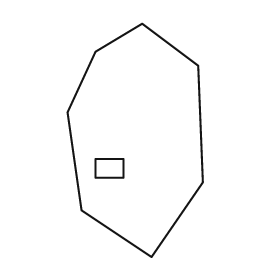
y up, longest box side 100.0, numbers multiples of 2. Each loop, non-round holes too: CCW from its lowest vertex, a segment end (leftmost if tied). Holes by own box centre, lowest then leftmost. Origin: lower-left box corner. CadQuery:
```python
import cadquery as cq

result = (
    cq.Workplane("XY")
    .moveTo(36.0, 0.0)
    .lineTo(58.0, 32.0)
    .lineTo(56.0, 82.0)
    .lineTo(32.0, 100.0)
    .lineTo(12.0, 88.0)
    .lineTo(0.0, 62.0)
    .lineTo(6.0, 20.0)
    .close()
    .moveTo(12.0, 34.0)
    .lineTo(24.0, 34.0)
    .lineTo(24.0, 42.0)
    .lineTo(12.0, 42.0)
    .close()
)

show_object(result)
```